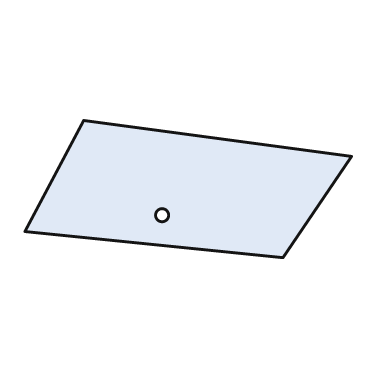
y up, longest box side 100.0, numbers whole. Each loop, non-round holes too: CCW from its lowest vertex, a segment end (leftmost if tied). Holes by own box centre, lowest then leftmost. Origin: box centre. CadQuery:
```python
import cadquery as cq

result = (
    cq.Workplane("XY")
    .moveTo(29.0, -21.0)
    .lineTo(50.0, 10.0)
    .lineTo(-32.0, 21.0)
    .lineTo(-50.0, -13.0)
    .close()
    .moveTo(-8.0, -8.0)
    .circle(2.0)
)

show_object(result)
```